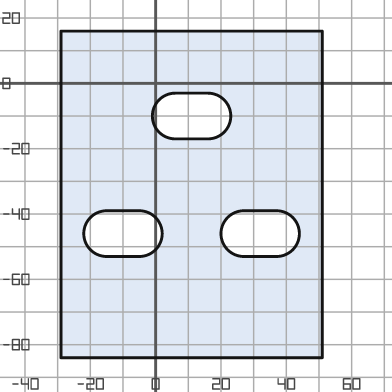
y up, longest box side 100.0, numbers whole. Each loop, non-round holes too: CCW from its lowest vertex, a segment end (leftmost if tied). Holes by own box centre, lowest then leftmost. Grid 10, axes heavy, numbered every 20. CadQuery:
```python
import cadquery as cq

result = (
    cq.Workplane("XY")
    .moveTo(-29.0, -84.0)
    .lineTo(51.0, -84.0)
    .lineTo(51.0, 16.0)
    .lineTo(-29.0, 16.0)
    .close()
    .moveTo(-15.0, -53.0)
    .lineTo(-5.0, -53.0)
    .threePointArc((2.0, -46.0), (-5.0, -39.0))
    .lineTo(-15.0, -39.0)
    .threePointArc((-22.0, -46.0), (-15.0, -53.0))
    .close()
    .moveTo(27.0, -53.0)
    .lineTo(37.0, -53.0)
    .threePointArc((44.0, -46.0), (37.0, -39.0))
    .lineTo(27.0, -39.0)
    .threePointArc((20.0, -46.0), (27.0, -53.0))
    .close()
    .moveTo(6.0, -17.0)
    .lineTo(16.0, -17.0)
    .threePointArc((23.0, -10.0), (16.0, -3.0))
    .lineTo(6.0, -3.0)
    .threePointArc((-1.0, -10.0), (6.0, -17.0))
    .close()
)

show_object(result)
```